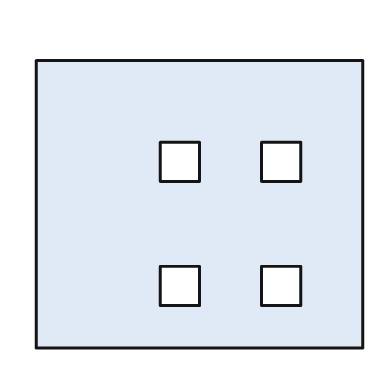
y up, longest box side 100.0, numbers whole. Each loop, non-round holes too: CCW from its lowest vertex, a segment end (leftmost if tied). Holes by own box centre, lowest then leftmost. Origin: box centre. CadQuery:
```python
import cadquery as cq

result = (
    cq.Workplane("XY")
    .moveTo(-50.0, -44.0)
    .lineTo(50.0, -44.0)
    .lineTo(50.0, 44.0)
    .lineTo(-50.0, 44.0)
    .close()
    .moveTo(-12.0, -31.0)
    .lineTo(0.0, -31.0)
    .lineTo(0.0, -19.0)
    .lineTo(-12.0, -19.0)
    .close()
    .moveTo(19.0, -31.0)
    .lineTo(31.0, -31.0)
    .lineTo(31.0, -19.0)
    .lineTo(19.0, -19.0)
    .close()
    .moveTo(-12.0, 7.0)
    .lineTo(0.0, 7.0)
    .lineTo(0.0, 19.0)
    .lineTo(-12.0, 19.0)
    .close()
    .moveTo(19.0, 7.0)
    .lineTo(31.0, 7.0)
    .lineTo(31.0, 19.0)
    .lineTo(19.0, 19.0)
    .close()
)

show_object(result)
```